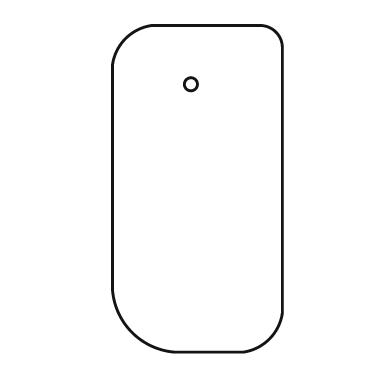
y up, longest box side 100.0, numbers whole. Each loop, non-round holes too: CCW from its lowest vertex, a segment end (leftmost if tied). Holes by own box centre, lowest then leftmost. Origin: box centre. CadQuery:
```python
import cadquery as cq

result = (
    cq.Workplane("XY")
    .moveTo(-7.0, -50.0)
    .lineTo(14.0, -50.0)
    .threePointArc((22.0, -46.0), (26.0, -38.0))
    .lineTo(26.0, 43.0)
    .threePointArc((24.0, 48.0), (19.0, 50.0))
    .lineTo(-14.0, 50.0)
    .threePointArc((-22.0, 46.0), (-26.0, 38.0))
    .lineTo(-26.0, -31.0)
    .threePointArc((-20.0, -44.0), (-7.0, -50.0))
    .close()
    .moveTo(-2.0, 32.0)
    .circle(2.0)
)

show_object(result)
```